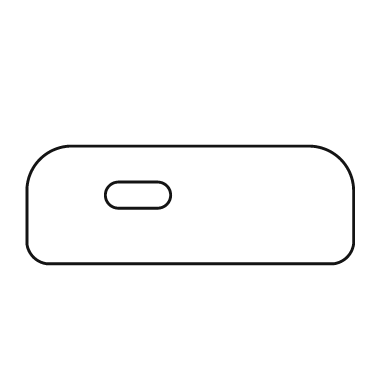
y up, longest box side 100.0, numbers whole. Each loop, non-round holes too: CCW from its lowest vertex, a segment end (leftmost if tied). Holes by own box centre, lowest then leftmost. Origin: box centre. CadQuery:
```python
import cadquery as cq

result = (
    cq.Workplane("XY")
    .moveTo(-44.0, -18.0)
    .lineTo(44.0, -18.0)
    .threePointArc((48.0, -16.0), (50.0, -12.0))
    .lineTo(50.0, 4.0)
    .threePointArc((46.0, 14.0), (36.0, 18.0))
    .lineTo(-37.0, 18.0)
    .threePointArc((-46.0, 14.0), (-50.0, 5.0))
    .lineTo(-50.0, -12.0)
    .threePointArc((-48.0, -16.0), (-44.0, -18.0))
    .close()
    .moveTo(-22.0, -1.0)
    .lineTo(-10.0, -1.0)
    .threePointArc((-6.0, 3.0), (-10.0, 7.0))
    .lineTo(-22.0, 7.0)
    .threePointArc((-26.0, 3.0), (-22.0, -1.0))
    .close()
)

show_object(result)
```